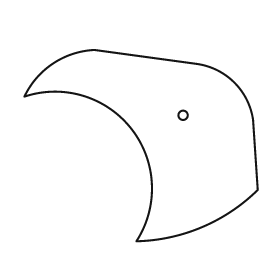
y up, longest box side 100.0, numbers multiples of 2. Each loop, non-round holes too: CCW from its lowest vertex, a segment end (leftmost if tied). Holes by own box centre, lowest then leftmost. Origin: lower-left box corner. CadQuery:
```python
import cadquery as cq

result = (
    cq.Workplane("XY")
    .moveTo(48.0, 0.0)
    .threePointArc((76.0, 6.0), (100.0, 22.0))
    .lineTo(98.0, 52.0)
    .threePointArc((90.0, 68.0), (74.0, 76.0))
    .lineTo(30.0, 82.0)
    .threePointArc((12.0, 76.0), (0.0, 62.0))
    .threePointArc((46.0, 48.0), (48.0, 0.0))
    .close()
    .moveTo(68.0, 54.0)
    .circle(2.0)
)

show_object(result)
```